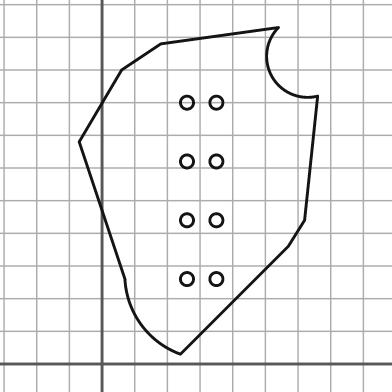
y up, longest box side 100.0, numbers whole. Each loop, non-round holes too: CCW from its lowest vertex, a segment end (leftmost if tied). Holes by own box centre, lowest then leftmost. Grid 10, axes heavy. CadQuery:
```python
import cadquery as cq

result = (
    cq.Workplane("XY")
    .moveTo(24.0, 3.0)
    .lineTo(57.0, 36.0)
    .lineTo(62.0, 44.0)
    .lineTo(66.0, 82.0)
    .threePointArc((52.0, 88.0), (54.0, 103.0))
    .lineTo(18.0, 98.0)
    .lineTo(6.0, 90.0)
    .lineTo(-7.0, 68.0)
    .lineTo(7.0, 26.0)
    .threePointArc((12.0, 12.0), (24.0, 3.0))
    .close()
    .moveTo(26.0, 26.0)
    .circle(2.0)
    .moveTo(35.0, 26.0)
    .circle(2.0)
    .moveTo(26.0, 44.0)
    .circle(2.0)
    .moveTo(35.0, 44.0)
    .circle(2.0)
    .moveTo(26.0, 62.0)
    .circle(2.0)
    .moveTo(35.0, 62.0)
    .circle(2.0)
    .moveTo(26.0, 80.0)
    .circle(2.0)
    .moveTo(35.0, 80.0)
    .circle(2.0)
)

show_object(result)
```